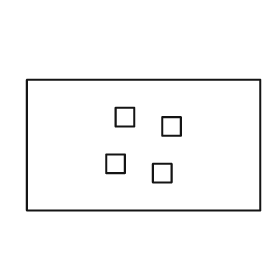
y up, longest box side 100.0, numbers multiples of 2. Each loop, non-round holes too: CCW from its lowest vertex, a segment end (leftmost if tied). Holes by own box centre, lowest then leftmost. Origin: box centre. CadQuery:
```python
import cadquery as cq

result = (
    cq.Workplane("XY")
    .moveTo(-50.0, -28.0)
    .lineTo(50.0, -28.0)
    .lineTo(50.0, 28.0)
    .lineTo(-50.0, 28.0)
    .close()
    .moveTo(4.0, -16.0)
    .lineTo(12.0, -16.0)
    .lineTo(12.0, -8.0)
    .lineTo(4.0, -8.0)
    .close()
    .moveTo(-16.0, -12.0)
    .lineTo(-8.0, -12.0)
    .lineTo(-8.0, -4.0)
    .lineTo(-16.0, -4.0)
    .close()
    .moveTo(8.0, 4.0)
    .lineTo(16.0, 4.0)
    .lineTo(16.0, 12.0)
    .lineTo(8.0, 12.0)
    .close()
    .moveTo(-12.0, 8.0)
    .lineTo(-4.0, 8.0)
    .lineTo(-4.0, 16.0)
    .lineTo(-12.0, 16.0)
    .close()
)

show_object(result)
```